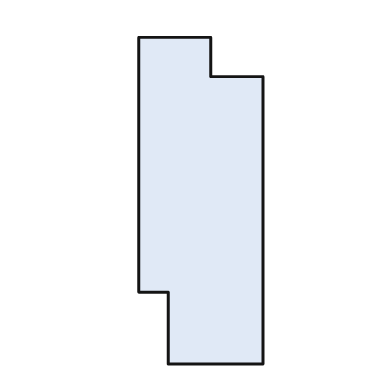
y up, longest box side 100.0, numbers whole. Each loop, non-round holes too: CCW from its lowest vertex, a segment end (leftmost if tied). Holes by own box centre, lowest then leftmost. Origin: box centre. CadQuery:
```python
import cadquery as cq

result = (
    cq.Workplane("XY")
    .moveTo(-10.0, -50.0)
    .lineTo(19.0, -50.0)
    .lineTo(19.0, 38.0)
    .lineTo(3.0, 38.0)
    .lineTo(3.0, 50.0)
    .lineTo(-19.0, 50.0)
    .lineTo(-19.0, -28.0)
    .lineTo(-10.0, -28.0)
    .close()
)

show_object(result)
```